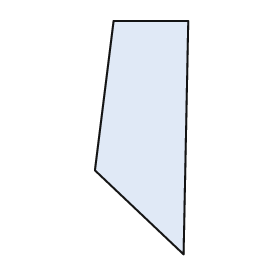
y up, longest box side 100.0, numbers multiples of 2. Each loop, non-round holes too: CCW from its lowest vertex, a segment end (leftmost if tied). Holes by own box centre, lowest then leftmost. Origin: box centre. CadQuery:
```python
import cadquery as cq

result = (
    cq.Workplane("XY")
    .moveTo(18.0, -50.0)
    .lineTo(20.0, 50.0)
    .lineTo(-12.0, 50.0)
    .lineTo(-20.0, -14.0)
    .close()
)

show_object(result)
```